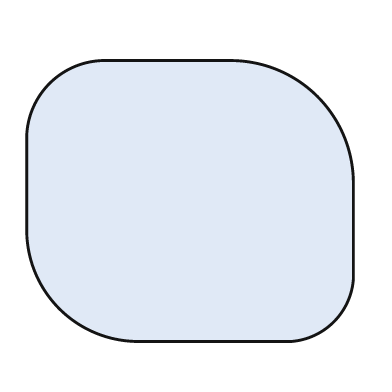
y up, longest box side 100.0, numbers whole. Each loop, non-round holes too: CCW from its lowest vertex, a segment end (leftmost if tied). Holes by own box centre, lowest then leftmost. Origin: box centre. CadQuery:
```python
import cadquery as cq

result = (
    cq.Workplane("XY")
    .moveTo(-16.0, -43.0)
    .lineTo(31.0, -43.0)
    .threePointArc((44.0, -37.0), (50.0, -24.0))
    .lineTo(50.0, 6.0)
    .threePointArc((39.0, 32.0), (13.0, 43.0))
    .lineTo(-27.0, 43.0)
    .threePointArc((-43.0, 36.0), (-50.0, 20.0))
    .lineTo(-50.0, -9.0)
    .threePointArc((-40.0, -33.0), (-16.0, -43.0))
    .close()
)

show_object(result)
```